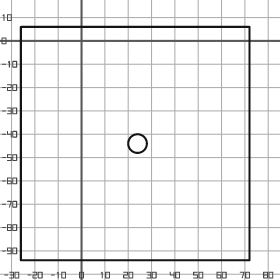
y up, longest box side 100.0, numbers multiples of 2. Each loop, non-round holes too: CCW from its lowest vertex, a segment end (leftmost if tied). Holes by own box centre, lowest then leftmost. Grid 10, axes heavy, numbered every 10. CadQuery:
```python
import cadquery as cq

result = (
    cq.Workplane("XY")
    .moveTo(-26.0, -94.0)
    .lineTo(72.0, -94.0)
    .lineTo(72.0, 6.0)
    .lineTo(-26.0, 6.0)
    .close()
    .moveTo(24.0, -44.0)
    .circle(4.0)
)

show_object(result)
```